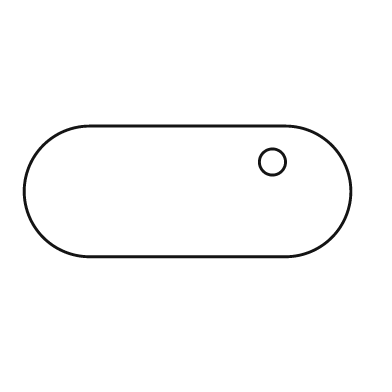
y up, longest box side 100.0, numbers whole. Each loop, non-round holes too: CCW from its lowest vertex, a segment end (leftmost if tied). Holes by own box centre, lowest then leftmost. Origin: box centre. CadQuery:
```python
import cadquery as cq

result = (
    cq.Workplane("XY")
    .moveTo(-30.0, -20.0)
    .lineTo(30.0, -20.0)
    .threePointArc((50.0, 0.0), (30.0, 20.0))
    .lineTo(-30.0, 20.0)
    .threePointArc((-50.0, 0.0), (-30.0, -20.0))
    .close()
    .moveTo(26.0, 9.0)
    .circle(4.0)
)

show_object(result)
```